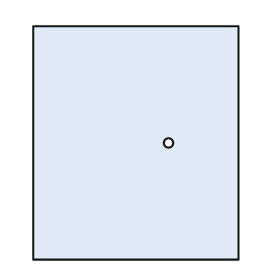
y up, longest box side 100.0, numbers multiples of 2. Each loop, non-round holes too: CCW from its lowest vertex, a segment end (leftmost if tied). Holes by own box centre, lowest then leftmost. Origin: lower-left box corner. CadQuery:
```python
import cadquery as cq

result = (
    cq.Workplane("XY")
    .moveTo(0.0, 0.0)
    .lineTo(88.0, 0.0)
    .lineTo(88.0, 100.0)
    .lineTo(0.0, 100.0)
    .close()
    .moveTo(58.0, 50.0)
    .circle(2.0)
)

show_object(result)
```